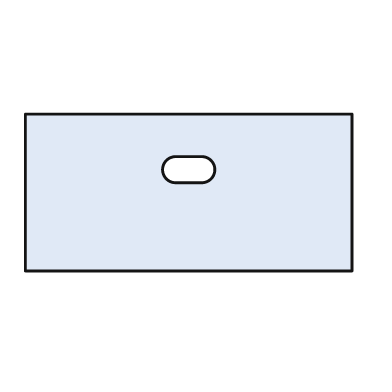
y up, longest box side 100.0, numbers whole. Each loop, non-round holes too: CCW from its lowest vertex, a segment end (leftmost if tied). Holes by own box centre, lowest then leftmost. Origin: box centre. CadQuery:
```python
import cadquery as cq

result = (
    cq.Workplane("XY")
    .moveTo(-50.0, -24.0)
    .lineTo(50.0, -24.0)
    .lineTo(50.0, 24.0)
    .lineTo(-50.0, 24.0)
    .close()
    .moveTo(-4.0, 3.0)
    .lineTo(4.0, 3.0)
    .threePointArc((8.0, 7.0), (4.0, 11.0))
    .lineTo(-4.0, 11.0)
    .threePointArc((-8.0, 7.0), (-4.0, 3.0))
    .close()
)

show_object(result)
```